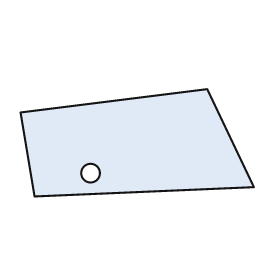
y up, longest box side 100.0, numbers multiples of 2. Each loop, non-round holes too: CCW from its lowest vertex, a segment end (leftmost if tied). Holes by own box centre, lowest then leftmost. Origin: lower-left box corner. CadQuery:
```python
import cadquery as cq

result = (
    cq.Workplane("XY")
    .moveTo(6.0, 0.0)
    .lineTo(100.0, 4.0)
    .lineTo(80.0, 46.0)
    .lineTo(0.0, 36.0)
    .close()
    .moveTo(30.0, 10.0)
    .circle(4.0)
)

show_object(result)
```